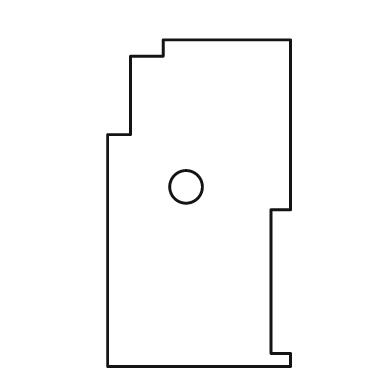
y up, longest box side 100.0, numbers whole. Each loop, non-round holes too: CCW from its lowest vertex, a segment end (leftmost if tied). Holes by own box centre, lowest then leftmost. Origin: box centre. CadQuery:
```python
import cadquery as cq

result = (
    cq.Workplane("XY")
    .moveTo(-28.0, -50.0)
    .lineTo(28.0, -50.0)
    .lineTo(28.0, -46.0)
    .lineTo(22.0, -46.0)
    .lineTo(22.0, -2.0)
    .lineTo(28.0, -2.0)
    .lineTo(28.0, 50.0)
    .lineTo(-11.0, 50.0)
    .lineTo(-11.0, 45.0)
    .lineTo(-21.0, 45.0)
    .lineTo(-21.0, 21.0)
    .lineTo(-28.0, 21.0)
    .close()
    .moveTo(-4.0, 5.0)
    .circle(5.0)
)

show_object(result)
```